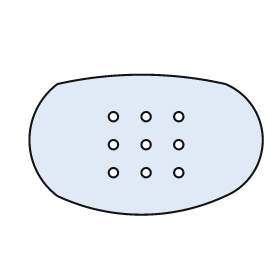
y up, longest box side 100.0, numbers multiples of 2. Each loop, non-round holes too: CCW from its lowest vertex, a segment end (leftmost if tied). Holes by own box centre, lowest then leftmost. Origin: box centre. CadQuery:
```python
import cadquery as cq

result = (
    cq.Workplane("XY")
    .moveTo(-38.0, -22.0)
    .threePointArc((-2.0, -30.0), (34.0, -22.0))
    .threePointArc((50.0, 2.0), (34.0, 26.0))
    .threePointArc((-2.0, 30.0), (-38.0, 26.0))
    .threePointArc((-50.0, 2.0), (-38.0, -22.0))
    .close()
    .moveTo(-14.0, -12.0)
    .circle(2.0)
    .moveTo(0.0, -12.0)
    .circle(2.0)
    .moveTo(14.0, -12.0)
    .circle(2.0)
    .moveTo(-14.0, 0.0)
    .circle(2.0)
    .moveTo(0.0, 0.0)
    .circle(2.0)
    .moveTo(14.0, 0.0)
    .circle(2.0)
    .moveTo(-14.0, 12.0)
    .circle(2.0)
    .moveTo(0.0, 12.0)
    .circle(2.0)
    .moveTo(14.0, 12.0)
    .circle(2.0)
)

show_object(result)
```